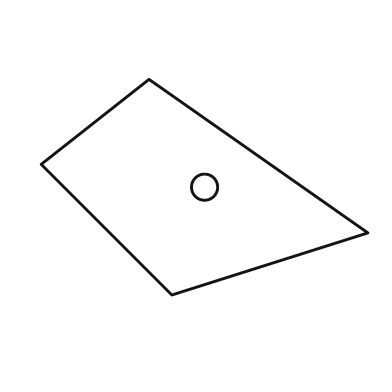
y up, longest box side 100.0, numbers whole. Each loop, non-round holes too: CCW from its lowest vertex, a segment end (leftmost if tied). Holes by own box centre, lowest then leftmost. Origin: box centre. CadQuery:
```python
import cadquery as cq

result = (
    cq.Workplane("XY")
    .moveTo(-10.0, -33.0)
    .lineTo(50.0, -14.0)
    .lineTo(-17.0, 33.0)
    .lineTo(-50.0, 7.0)
    .close()
    .moveTo(0.0, 0.0)
    .circle(4.0)
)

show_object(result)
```